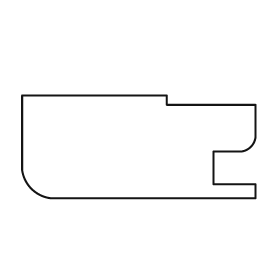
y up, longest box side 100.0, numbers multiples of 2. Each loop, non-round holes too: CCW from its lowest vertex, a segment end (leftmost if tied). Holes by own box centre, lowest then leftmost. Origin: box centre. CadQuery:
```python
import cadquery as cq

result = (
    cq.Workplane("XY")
    .moveTo(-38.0, -22.0)
    .lineTo(50.0, -22.0)
    .lineTo(50.0, -16.0)
    .lineTo(32.0, -16.0)
    .lineTo(32.0, -2.0)
    .lineTo(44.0, -2.0)
    .threePointArc((48.0, 0.0), (50.0, 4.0))
    .lineTo(50.0, 18.0)
    .lineTo(12.0, 18.0)
    .lineTo(12.0, 22.0)
    .lineTo(-50.0, 22.0)
    .lineTo(-50.0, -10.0)
    .threePointArc((-46.0, -18.0), (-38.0, -22.0))
    .close()
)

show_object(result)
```